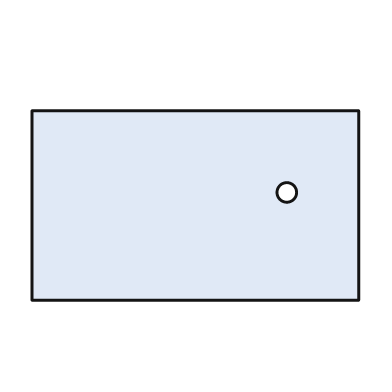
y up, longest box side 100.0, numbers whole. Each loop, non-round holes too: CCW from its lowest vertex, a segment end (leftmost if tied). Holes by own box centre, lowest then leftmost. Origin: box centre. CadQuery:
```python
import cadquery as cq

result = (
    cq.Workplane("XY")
    .moveTo(-50.0, -29.0)
    .lineTo(50.0, -29.0)
    .lineTo(50.0, 29.0)
    .lineTo(-50.0, 29.0)
    .close()
    .moveTo(28.0, 4.0)
    .circle(3.0)
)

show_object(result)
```